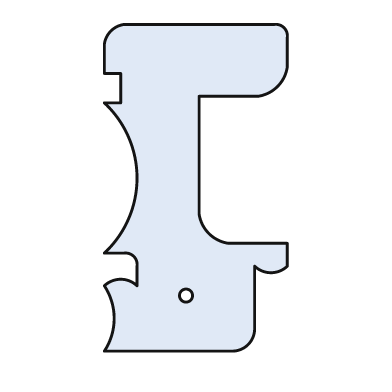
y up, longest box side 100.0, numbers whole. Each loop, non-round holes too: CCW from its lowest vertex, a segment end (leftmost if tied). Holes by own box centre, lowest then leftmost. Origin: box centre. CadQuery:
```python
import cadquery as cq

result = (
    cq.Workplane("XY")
    .moveTo(-28.0, -50.0)
    .lineTo(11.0, -50.0)
    .threePointArc((16.0, -48.0), (18.0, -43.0))
    .lineTo(18.0, -24.0)
    .threePointArc((23.0, -26.0), (28.0, -24.0))
    .lineTo(28.0, -17.0)
    .lineTo(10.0, -17.0)
    .threePointArc((4.0, -14.0), (1.0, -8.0))
    .lineTo(1.0, 28.0)
    .lineTo(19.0, 28.0)
    .threePointArc((25.0, 31.0), (28.0, 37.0))
    .lineTo(28.0, 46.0)
    .threePointArc((27.0, 49.0), (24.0, 50.0))
    .lineTo(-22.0, 50.0)
    .threePointArc((-26.0, 48.0), (-28.0, 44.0))
    .lineTo(-28.0, 35.0)
    .lineTo(-23.0, 35.0)
    .lineTo(-23.0, 26.0)
    .lineTo(-28.0, 26.0)
    .threePointArc((-18.0, 3.0), (-28.0, -20.0))
    .lineTo(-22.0, -20.0)
    .threePointArc((-19.0, -21.0), (-18.0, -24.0))
    .lineTo(-18.0, -30.0)
    .threePointArc((-23.0, -28.0), (-28.0, -30.0))
    .threePointArc((-25.0, -40.0), (-28.0, -50.0))
    .close()
    .moveTo(-3.0, -33.0)
    .circle(2.0)
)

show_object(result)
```